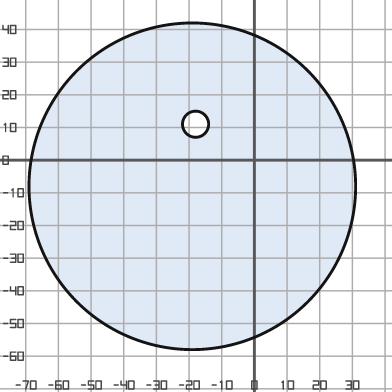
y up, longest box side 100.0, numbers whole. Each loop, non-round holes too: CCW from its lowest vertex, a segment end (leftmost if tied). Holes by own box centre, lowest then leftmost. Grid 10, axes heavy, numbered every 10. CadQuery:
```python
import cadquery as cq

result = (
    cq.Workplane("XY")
    .moveTo(-19.0, -8.0)
    .circle(50.0)
    .moveTo(-18.0, 11.0)
    .circle(4.0)
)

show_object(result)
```